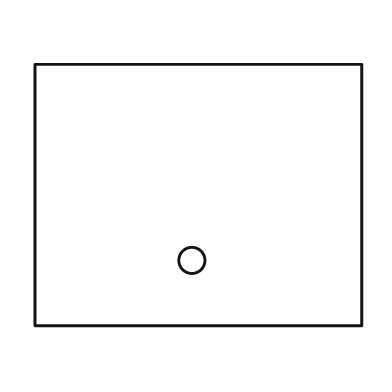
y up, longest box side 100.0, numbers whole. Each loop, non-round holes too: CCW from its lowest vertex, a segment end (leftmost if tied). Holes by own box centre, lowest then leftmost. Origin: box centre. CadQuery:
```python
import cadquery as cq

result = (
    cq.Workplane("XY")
    .moveTo(-50.0, -40.0)
    .lineTo(50.0, -40.0)
    .lineTo(50.0, 40.0)
    .lineTo(-50.0, 40.0)
    .close()
    .moveTo(-2.0, -20.0)
    .circle(4.0)
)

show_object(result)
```